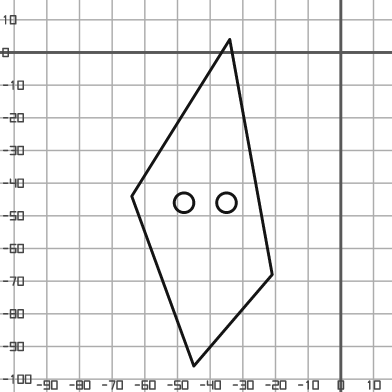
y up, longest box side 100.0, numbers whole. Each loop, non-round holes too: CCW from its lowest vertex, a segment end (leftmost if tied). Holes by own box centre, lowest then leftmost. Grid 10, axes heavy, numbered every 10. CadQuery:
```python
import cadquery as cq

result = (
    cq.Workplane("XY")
    .moveTo(-45.0, -96.0)
    .lineTo(-21.0, -68.0)
    .lineTo(-34.0, 4.0)
    .lineTo(-64.0, -44.0)
    .close()
    .moveTo(-48.0, -46.0)
    .circle(3.0)
    .moveTo(-35.0, -46.0)
    .circle(3.0)
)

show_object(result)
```